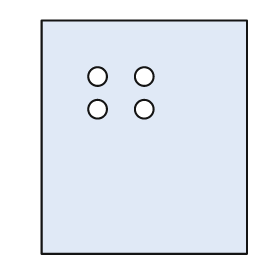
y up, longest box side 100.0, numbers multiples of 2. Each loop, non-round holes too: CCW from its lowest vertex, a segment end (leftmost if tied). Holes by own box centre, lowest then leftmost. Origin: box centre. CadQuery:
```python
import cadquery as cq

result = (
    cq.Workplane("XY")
    .moveTo(-44.0, -50.0)
    .lineTo(44.0, -50.0)
    .lineTo(44.0, 50.0)
    .lineTo(-44.0, 50.0)
    .close()
    .moveTo(-20.0, 12.0)
    .circle(4.0)
    .moveTo(0.0, 12.0)
    .circle(4.0)
    .moveTo(-20.0, 26.0)
    .circle(4.0)
    .moveTo(0.0, 26.0)
    .circle(4.0)
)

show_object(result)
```